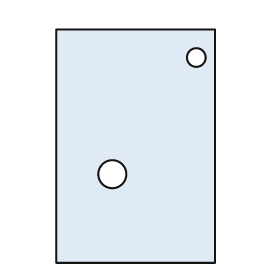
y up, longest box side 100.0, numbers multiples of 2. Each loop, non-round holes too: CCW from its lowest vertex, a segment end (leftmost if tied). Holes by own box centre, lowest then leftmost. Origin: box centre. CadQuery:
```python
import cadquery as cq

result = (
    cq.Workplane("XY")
    .moveTo(-34.0, -50.0)
    .lineTo(34.0, -50.0)
    .lineTo(34.0, 50.0)
    .lineTo(-34.0, 50.0)
    .close()
    .moveTo(-10.0, -12.0)
    .circle(6.0)
    .moveTo(26.0, 38.0)
    .circle(4.0)
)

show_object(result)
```